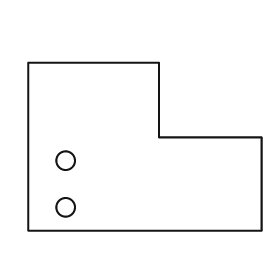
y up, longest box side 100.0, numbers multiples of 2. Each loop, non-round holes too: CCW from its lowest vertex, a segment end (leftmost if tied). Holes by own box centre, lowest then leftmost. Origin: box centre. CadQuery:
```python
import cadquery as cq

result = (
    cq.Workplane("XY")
    .moveTo(-50.0, -36.0)
    .lineTo(50.0, -36.0)
    .lineTo(50.0, 4.0)
    .lineTo(6.0, 4.0)
    .lineTo(6.0, 36.0)
    .lineTo(-50.0, 36.0)
    .close()
    .moveTo(-34.0, -26.0)
    .circle(4.0)
    .moveTo(-34.0, -6.0)
    .circle(4.0)
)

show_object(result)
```